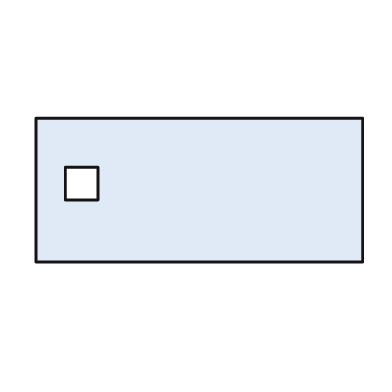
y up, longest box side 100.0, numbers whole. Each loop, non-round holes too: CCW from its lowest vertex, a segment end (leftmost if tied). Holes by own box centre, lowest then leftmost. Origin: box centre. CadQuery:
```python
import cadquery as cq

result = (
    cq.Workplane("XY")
    .moveTo(-50.0, -22.0)
    .lineTo(50.0, -22.0)
    .lineTo(50.0, 22.0)
    .lineTo(-50.0, 22.0)
    .close()
    .moveTo(-41.0, -3.0)
    .lineTo(-31.0, -3.0)
    .lineTo(-31.0, 7.0)
    .lineTo(-41.0, 7.0)
    .close()
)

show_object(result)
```